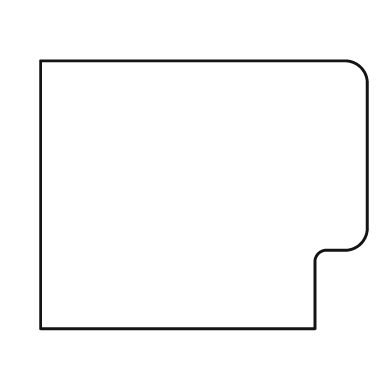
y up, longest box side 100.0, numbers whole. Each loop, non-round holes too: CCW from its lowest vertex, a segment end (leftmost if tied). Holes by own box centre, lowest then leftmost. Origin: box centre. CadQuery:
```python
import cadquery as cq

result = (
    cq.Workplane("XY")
    .moveTo(-50.0, -41.0)
    .lineTo(34.0, -41.0)
    .lineTo(34.0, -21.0)
    .threePointArc((35.0, -18.0), (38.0, -17.0))
    .lineTo(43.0, -17.0)
    .threePointArc((48.0, -15.0), (50.0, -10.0))
    .lineTo(50.0, 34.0)
    .threePointArc((48.0, 39.0), (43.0, 41.0))
    .lineTo(-50.0, 41.0)
    .close()
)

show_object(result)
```